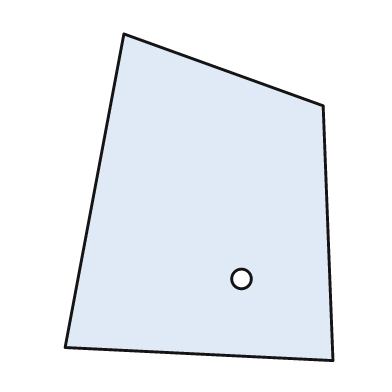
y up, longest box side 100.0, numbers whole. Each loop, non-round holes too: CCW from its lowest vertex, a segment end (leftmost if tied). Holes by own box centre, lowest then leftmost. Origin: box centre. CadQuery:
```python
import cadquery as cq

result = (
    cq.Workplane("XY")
    .moveTo(41.0, -50.0)
    .lineTo(38.0, 28.0)
    .lineTo(-23.0, 50.0)
    .lineTo(-41.0, -46.0)
    .close()
    .moveTo(13.0, -25.0)
    .circle(3.0)
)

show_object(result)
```